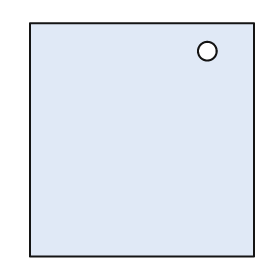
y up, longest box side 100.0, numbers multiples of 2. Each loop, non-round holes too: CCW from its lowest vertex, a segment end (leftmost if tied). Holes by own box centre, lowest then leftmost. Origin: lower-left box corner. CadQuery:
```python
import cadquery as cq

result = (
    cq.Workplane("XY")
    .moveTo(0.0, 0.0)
    .lineTo(96.0, 0.0)
    .lineTo(96.0, 100.0)
    .lineTo(0.0, 100.0)
    .close()
    .moveTo(76.0, 88.0)
    .circle(4.0)
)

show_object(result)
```